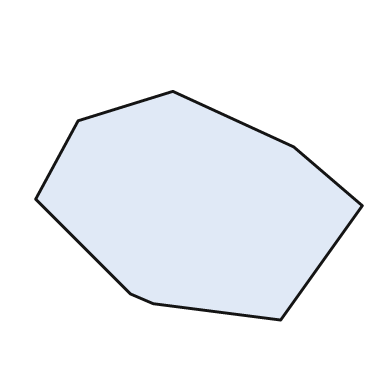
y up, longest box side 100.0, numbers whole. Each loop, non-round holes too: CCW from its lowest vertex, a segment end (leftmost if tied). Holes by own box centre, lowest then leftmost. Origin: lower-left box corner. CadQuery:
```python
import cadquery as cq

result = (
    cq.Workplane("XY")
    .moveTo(75.0, 0.0)
    .lineTo(100.0, 35.0)
    .lineTo(79.0, 53.0)
    .lineTo(42.0, 70.0)
    .lineTo(13.0, 61.0)
    .lineTo(0.0, 37.0)
    .lineTo(29.0, 8.0)
    .lineTo(36.0, 5.0)
    .close()
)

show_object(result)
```